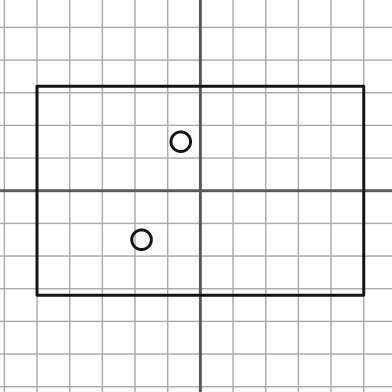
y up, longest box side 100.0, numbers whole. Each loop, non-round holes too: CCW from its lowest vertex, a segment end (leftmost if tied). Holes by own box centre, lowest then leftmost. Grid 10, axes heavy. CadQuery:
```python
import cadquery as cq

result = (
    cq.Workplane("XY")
    .moveTo(-50.0, -32.0)
    .lineTo(50.0, -32.0)
    .lineTo(50.0, 32.0)
    .lineTo(-50.0, 32.0)
    .close()
    .moveTo(-18.0, -15.0)
    .circle(3.0)
    .moveTo(-6.0, 15.0)
    .circle(3.0)
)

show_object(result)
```